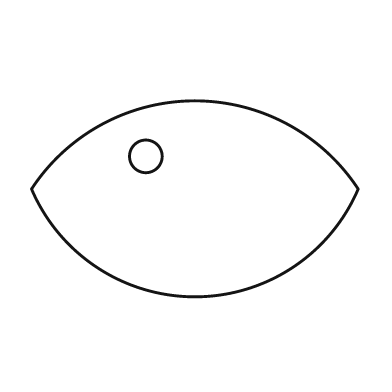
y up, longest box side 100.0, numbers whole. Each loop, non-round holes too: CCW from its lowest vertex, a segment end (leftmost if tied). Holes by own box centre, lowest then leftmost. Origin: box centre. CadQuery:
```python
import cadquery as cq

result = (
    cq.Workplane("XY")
    .moveTo(-50.0, 3.0)
    .threePointArc((0.0, -30.0), (50.0, 3.0))
    .threePointArc((0.0, 30.0), (-50.0, 3.0))
    .close()
    .moveTo(-15.0, 13.0)
    .circle(5.0)
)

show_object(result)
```